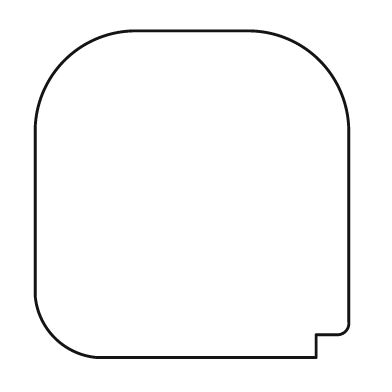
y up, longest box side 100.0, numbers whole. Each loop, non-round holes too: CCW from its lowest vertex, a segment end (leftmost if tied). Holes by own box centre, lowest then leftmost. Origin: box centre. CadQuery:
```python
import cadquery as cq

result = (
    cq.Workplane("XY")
    .moveTo(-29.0, -50.0)
    .lineTo(38.0, -50.0)
    .lineTo(38.0, -43.0)
    .lineTo(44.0, -43.0)
    .threePointArc((47.0, -42.0), (48.0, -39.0))
    .lineTo(48.0, 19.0)
    .threePointArc((39.0, 41.0), (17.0, 50.0))
    .lineTo(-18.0, 50.0)
    .threePointArc((-39.0, 41.0), (-48.0, 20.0))
    .lineTo(-48.0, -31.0)
    .threePointArc((-42.0, -44.0), (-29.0, -50.0))
    .close()
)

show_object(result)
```